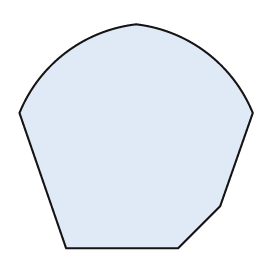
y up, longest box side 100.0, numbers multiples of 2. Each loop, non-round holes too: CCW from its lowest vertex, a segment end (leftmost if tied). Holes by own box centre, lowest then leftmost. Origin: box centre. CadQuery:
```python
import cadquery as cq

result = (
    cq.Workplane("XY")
    .moveTo(-30.0, -48.0)
    .lineTo(18.0, -48.0)
    .lineTo(36.0, -30.0)
    .lineTo(50.0, 10.0)
    .threePointArc((30.0, 36.0), (0.0, 48.0))
    .threePointArc((-30.0, 36.0), (-50.0, 10.0))
    .close()
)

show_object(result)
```